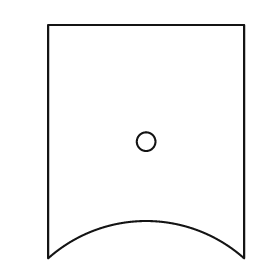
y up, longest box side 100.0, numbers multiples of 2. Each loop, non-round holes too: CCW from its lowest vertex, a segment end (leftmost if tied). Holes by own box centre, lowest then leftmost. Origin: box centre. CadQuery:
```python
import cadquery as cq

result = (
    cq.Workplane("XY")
    .moveTo(-42.0, -50.0)
    .threePointArc((0.0, -34.0), (42.0, -50.0))
    .lineTo(42.0, 50.0)
    .lineTo(-42.0, 50.0)
    .close()
    .moveTo(0.0, 0.0)
    .circle(4.0)
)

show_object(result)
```